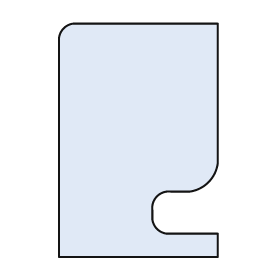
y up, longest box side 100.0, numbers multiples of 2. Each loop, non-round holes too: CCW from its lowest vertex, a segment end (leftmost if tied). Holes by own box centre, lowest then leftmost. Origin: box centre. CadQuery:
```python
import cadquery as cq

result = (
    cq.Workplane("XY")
    .moveTo(-34.0, -50.0)
    .lineTo(34.0, -50.0)
    .lineTo(34.0, -40.0)
    .lineTo(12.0, -40.0)
    .threePointArc((8.0, -38.0), (6.0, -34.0))
    .lineTo(6.0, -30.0)
    .threePointArc((8.0, -24.0), (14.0, -22.0))
    .lineTo(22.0, -22.0)
    .threePointArc((30.0, -18.0), (34.0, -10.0))
    .lineTo(34.0, 50.0)
    .lineTo(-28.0, 50.0)
    .threePointArc((-32.0, 48.0), (-34.0, 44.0))
    .close()
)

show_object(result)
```